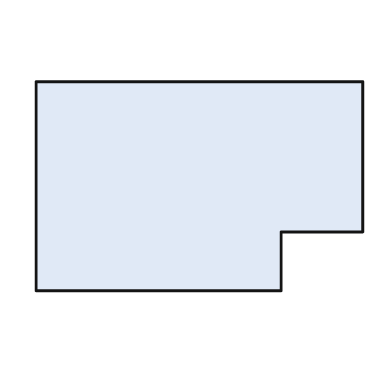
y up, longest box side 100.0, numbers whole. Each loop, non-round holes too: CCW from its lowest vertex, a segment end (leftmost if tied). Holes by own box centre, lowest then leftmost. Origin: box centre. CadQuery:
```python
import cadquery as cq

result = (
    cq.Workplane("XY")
    .moveTo(-50.0, -32.0)
    .lineTo(25.0, -32.0)
    .lineTo(25.0, -14.0)
    .lineTo(50.0, -14.0)
    .lineTo(50.0, 32.0)
    .lineTo(-50.0, 32.0)
    .close()
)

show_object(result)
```